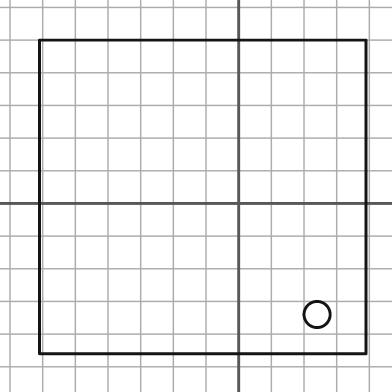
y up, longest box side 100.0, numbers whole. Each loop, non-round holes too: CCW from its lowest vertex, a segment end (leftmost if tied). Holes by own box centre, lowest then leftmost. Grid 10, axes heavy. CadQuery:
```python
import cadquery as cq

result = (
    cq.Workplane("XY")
    .moveTo(-61.0, -46.0)
    .lineTo(39.0, -46.0)
    .lineTo(39.0, 50.0)
    .lineTo(-61.0, 50.0)
    .close()
    .moveTo(24.0, -34.0)
    .circle(4.0)
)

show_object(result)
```